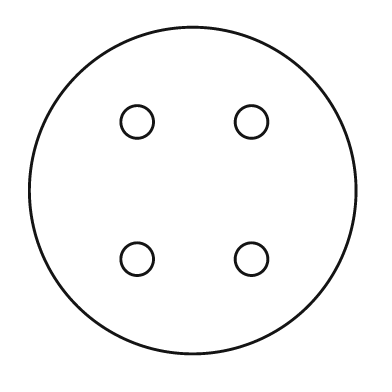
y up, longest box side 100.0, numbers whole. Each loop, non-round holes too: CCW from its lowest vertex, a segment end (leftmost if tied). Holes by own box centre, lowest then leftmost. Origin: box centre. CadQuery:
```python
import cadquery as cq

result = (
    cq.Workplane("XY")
    .moveTo(0.0, 0.0)
    .circle(50.0)
    .moveTo(-17.0, -21.0)
    .circle(5.0)
    .moveTo(18.0, -21.0)
    .circle(5.0)
    .moveTo(-17.0, 21.0)
    .circle(5.0)
    .moveTo(18.0, 21.0)
    .circle(5.0)
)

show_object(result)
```